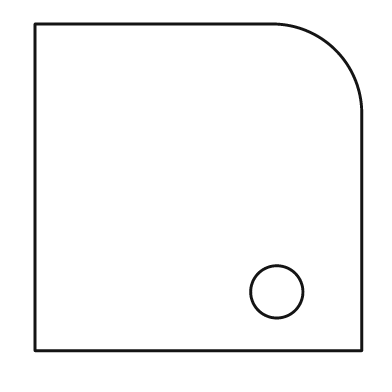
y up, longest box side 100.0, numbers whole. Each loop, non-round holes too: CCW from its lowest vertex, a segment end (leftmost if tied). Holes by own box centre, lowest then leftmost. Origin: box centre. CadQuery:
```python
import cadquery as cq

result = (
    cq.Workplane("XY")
    .moveTo(-50.0, -50.0)
    .lineTo(50.0, -50.0)
    .lineTo(50.0, 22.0)
    .threePointArc((42.0, 42.0), (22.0, 50.0))
    .lineTo(-50.0, 50.0)
    .close()
    .moveTo(24.0, -32.0)
    .circle(8.0)
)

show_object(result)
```